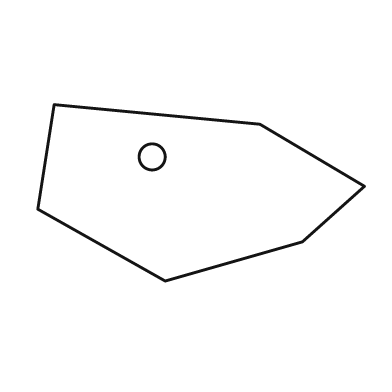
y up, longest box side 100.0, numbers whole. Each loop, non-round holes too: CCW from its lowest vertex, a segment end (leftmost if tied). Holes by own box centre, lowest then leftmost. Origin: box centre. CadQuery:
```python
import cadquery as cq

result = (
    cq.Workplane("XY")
    .moveTo(-11.0, -27.0)
    .lineTo(31.0, -15.0)
    .lineTo(50.0, 2.0)
    .lineTo(18.0, 21.0)
    .lineTo(-45.0, 27.0)
    .lineTo(-50.0, -5.0)
    .close()
    .moveTo(-15.0, 11.0)
    .circle(4.0)
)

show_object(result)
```